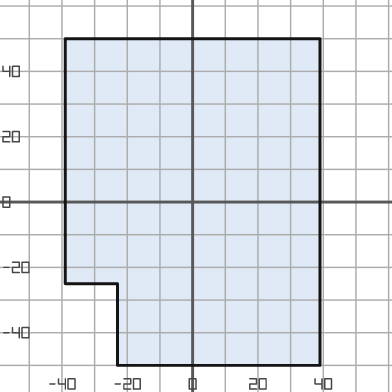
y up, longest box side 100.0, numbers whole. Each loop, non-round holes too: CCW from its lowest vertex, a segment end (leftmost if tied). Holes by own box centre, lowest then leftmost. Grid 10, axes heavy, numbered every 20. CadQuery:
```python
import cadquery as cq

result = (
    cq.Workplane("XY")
    .moveTo(-23.0, -50.0)
    .lineTo(39.0, -50.0)
    .lineTo(39.0, 50.0)
    .lineTo(-39.0, 50.0)
    .lineTo(-39.0, -25.0)
    .lineTo(-23.0, -25.0)
    .close()
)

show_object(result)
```